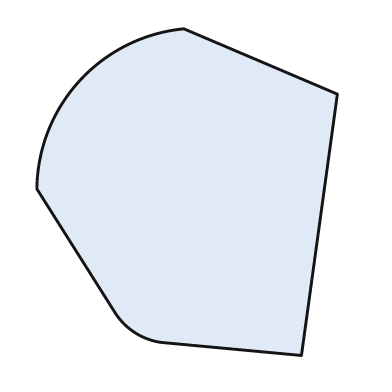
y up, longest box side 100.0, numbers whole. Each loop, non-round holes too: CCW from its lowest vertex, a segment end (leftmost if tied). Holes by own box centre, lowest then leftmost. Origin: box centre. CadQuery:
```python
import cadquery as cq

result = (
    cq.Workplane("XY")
    .moveTo(35.0, -50.0)
    .lineTo(46.0, 30.0)
    .lineTo(-1.0, 50.0)
    .threePointArc((-33.0, 34.0), (-46.0, 1.0))
    .lineTo(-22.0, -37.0)
    .threePointArc((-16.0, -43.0), (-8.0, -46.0))
    .close()
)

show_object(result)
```